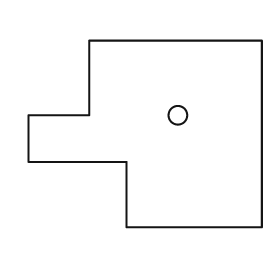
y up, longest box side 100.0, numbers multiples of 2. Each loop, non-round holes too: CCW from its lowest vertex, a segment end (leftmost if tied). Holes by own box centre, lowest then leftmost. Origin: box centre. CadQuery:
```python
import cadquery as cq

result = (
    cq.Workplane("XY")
    .moveTo(-8.0, -40.0)
    .lineTo(50.0, -40.0)
    .lineTo(50.0, 40.0)
    .lineTo(-24.0, 40.0)
    .lineTo(-24.0, 8.0)
    .lineTo(-50.0, 8.0)
    .lineTo(-50.0, -12.0)
    .lineTo(-8.0, -12.0)
    .close()
    .moveTo(14.0, 8.0)
    .circle(4.0)
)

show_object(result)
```